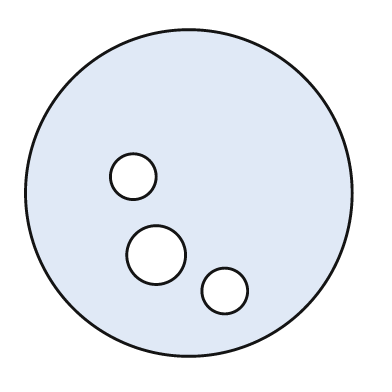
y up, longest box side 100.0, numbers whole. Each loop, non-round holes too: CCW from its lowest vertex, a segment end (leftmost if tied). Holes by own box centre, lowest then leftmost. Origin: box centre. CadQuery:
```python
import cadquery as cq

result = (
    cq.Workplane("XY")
    .moveTo(0.0, 0.0)
    .circle(50.0)
    .moveTo(11.0, -30.0)
    .circle(7.0)
    .moveTo(-10.0, -19.0)
    .circle(9.0)
    .moveTo(-17.0, 5.0)
    .circle(7.0)
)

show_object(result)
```